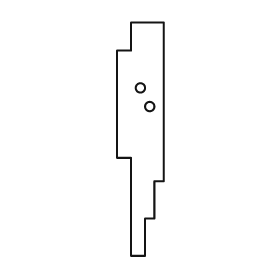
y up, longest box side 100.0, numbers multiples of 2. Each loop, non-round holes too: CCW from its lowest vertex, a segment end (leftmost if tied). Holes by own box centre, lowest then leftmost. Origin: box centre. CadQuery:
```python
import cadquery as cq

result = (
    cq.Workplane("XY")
    .moveTo(-4.0, -50.0)
    .lineTo(2.0, -50.0)
    .lineTo(2.0, -34.0)
    .lineTo(6.0, -34.0)
    .lineTo(6.0, -18.0)
    .lineTo(10.0, -18.0)
    .lineTo(10.0, 50.0)
    .lineTo(-4.0, 50.0)
    .lineTo(-4.0, 38.0)
    .lineTo(-10.0, 38.0)
    .lineTo(-10.0, -8.0)
    .lineTo(-4.0, -8.0)
    .close()
    .moveTo(4.0, 14.0)
    .circle(2.0)
    .moveTo(0.0, 22.0)
    .circle(2.0)
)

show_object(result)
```